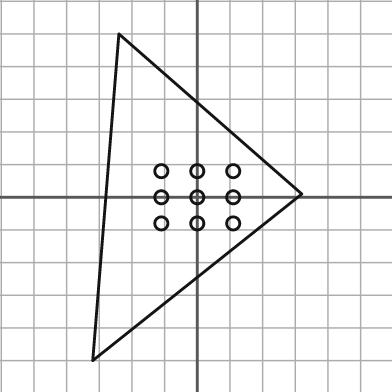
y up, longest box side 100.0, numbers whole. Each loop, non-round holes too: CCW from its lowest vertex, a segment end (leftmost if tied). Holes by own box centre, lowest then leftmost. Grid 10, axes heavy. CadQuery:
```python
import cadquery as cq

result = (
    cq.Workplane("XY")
    .moveTo(-32.0, -50.0)
    .lineTo(32.0, 1.0)
    .lineTo(-24.0, 50.0)
    .close()
    .moveTo(-11.0, -8.0)
    .circle(2.0)
    .moveTo(0.0, -8.0)
    .circle(2.0)
    .moveTo(11.0, -8.0)
    .circle(2.0)
    .moveTo(-11.0, 0.0)
    .circle(2.0)
    .moveTo(0.0, 0.0)
    .circle(2.0)
    .moveTo(11.0, 0.0)
    .circle(2.0)
    .moveTo(-11.0, 8.0)
    .circle(2.0)
    .moveTo(0.0, 8.0)
    .circle(2.0)
    .moveTo(11.0, 8.0)
    .circle(2.0)
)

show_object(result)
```